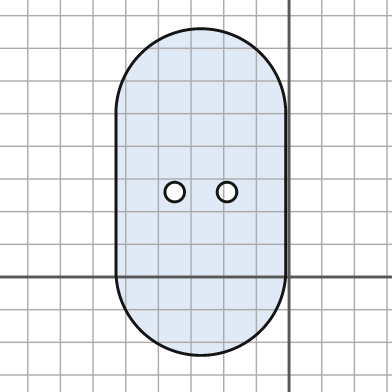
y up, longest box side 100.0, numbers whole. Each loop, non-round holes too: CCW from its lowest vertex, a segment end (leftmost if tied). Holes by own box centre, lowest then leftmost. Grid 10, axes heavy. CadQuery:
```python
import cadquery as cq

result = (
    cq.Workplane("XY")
    .moveTo(-53.0, 2.0)
    .threePointArc((-27.0, -24.0), (-1.0, 2.0))
    .lineTo(-1.0, 50.0)
    .threePointArc((-27.0, 76.0), (-53.0, 50.0))
    .close()
    .moveTo(-35.0, 26.0)
    .circle(3.0)
    .moveTo(-19.0, 26.0)
    .circle(3.0)
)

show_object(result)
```